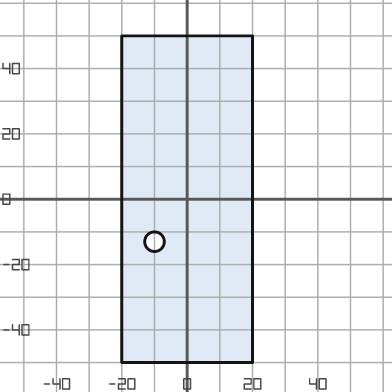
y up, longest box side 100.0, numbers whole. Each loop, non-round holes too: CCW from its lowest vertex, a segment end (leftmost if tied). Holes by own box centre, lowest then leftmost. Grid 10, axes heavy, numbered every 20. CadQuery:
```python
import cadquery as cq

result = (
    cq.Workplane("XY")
    .moveTo(-20.0, -50.0)
    .lineTo(20.0, -50.0)
    .lineTo(20.0, 50.0)
    .lineTo(-20.0, 50.0)
    .close()
    .moveTo(-10.0, -13.0)
    .circle(3.0)
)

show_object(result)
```